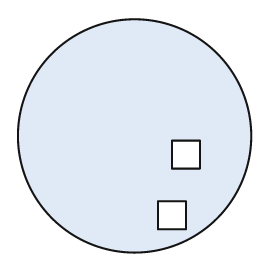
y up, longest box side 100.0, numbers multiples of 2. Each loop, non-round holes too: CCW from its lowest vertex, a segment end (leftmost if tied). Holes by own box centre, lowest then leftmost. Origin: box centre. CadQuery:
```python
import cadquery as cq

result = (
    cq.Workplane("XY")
    .moveTo(0.0, 0.0)
    .circle(50.0)
    .moveTo(10.0, -40.0)
    .lineTo(22.0, -40.0)
    .lineTo(22.0, -28.0)
    .lineTo(10.0, -28.0)
    .close()
    .moveTo(16.0, -14.0)
    .lineTo(28.0, -14.0)
    .lineTo(28.0, -2.0)
    .lineTo(16.0, -2.0)
    .close()
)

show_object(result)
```